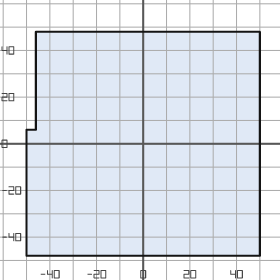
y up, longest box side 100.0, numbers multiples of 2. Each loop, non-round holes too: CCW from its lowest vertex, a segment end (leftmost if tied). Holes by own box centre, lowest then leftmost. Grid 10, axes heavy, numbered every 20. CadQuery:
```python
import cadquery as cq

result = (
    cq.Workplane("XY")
    .moveTo(-50.0, -48.0)
    .lineTo(50.0, -48.0)
    .lineTo(50.0, 48.0)
    .lineTo(-46.0, 48.0)
    .lineTo(-46.0, 6.0)
    .lineTo(-50.0, 6.0)
    .close()
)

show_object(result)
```